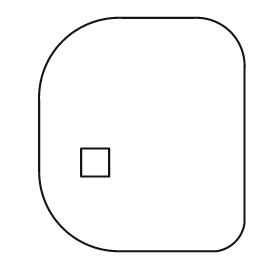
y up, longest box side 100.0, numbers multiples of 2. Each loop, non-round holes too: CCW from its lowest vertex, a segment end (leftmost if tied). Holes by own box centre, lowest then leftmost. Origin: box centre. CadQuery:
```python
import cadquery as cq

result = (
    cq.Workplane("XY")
    .moveTo(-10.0, -50.0)
    .lineTo(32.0, -50.0)
    .threePointArc((40.0, -46.0), (44.0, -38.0))
    .lineTo(44.0, 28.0)
    .threePointArc((38.0, 44.0), (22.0, 50.0))
    .lineTo(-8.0, 50.0)
    .threePointArc((-34.0, 40.0), (-44.0, 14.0))
    .lineTo(-44.0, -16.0)
    .threePointArc((-34.0, -40.0), (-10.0, -50.0))
    .close()
    .moveTo(-26.0, -18.0)
    .lineTo(-14.0, -18.0)
    .lineTo(-14.0, -6.0)
    .lineTo(-26.0, -6.0)
    .close()
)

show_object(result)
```